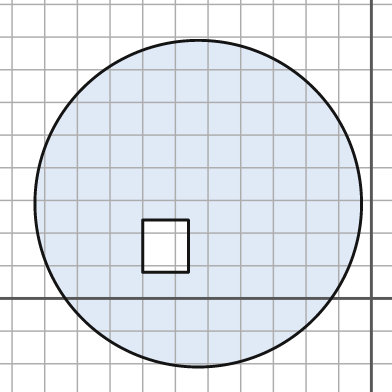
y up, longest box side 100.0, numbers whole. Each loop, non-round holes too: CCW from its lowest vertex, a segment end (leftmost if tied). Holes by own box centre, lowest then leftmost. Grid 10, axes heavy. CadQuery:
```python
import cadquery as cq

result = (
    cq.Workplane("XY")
    .moveTo(-53.0, 29.0)
    .circle(50.0)
    .moveTo(-70.0, 8.0)
    .lineTo(-56.0, 8.0)
    .lineTo(-56.0, 24.0)
    .lineTo(-70.0, 24.0)
    .close()
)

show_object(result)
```